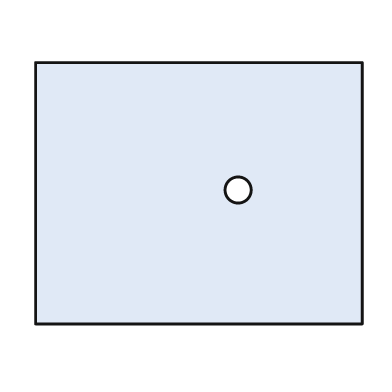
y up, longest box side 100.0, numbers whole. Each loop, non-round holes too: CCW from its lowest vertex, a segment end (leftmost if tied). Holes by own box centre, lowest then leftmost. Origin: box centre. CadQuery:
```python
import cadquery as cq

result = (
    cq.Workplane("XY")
    .moveTo(-50.0, -40.0)
    .lineTo(50.0, -40.0)
    .lineTo(50.0, 40.0)
    .lineTo(-50.0, 40.0)
    .close()
    .moveTo(12.0, 1.0)
    .circle(4.0)
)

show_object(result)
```